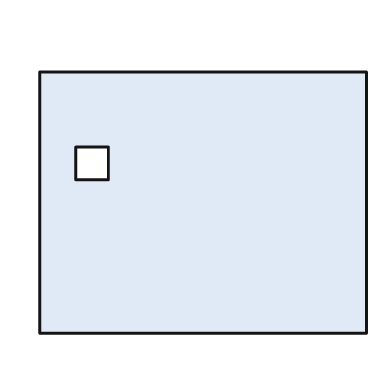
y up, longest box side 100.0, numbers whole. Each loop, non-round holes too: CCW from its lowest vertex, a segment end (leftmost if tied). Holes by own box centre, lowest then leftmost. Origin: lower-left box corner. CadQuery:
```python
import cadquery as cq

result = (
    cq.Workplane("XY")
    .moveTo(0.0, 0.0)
    .lineTo(100.0, 0.0)
    .lineTo(100.0, 80.0)
    .lineTo(0.0, 80.0)
    .close()
    .moveTo(11.0, 47.0)
    .lineTo(21.0, 47.0)
    .lineTo(21.0, 57.0)
    .lineTo(11.0, 57.0)
    .close()
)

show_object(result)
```